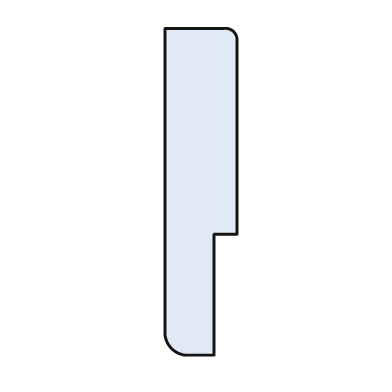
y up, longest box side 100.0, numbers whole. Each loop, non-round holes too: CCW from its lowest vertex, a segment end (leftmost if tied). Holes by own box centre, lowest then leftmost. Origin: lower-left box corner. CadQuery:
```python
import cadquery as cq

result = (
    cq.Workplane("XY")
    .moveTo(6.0, 0.0)
    .lineTo(15.0, 0.0)
    .lineTo(15.0, 37.0)
    .lineTo(22.0, 37.0)
    .lineTo(22.0, 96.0)
    .threePointArc((21.0, 99.0), (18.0, 100.0))
    .lineTo(0.0, 100.0)
    .lineTo(0.0, 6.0)
    .threePointArc((2.0, 2.0), (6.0, 0.0))
    .close()
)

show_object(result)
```